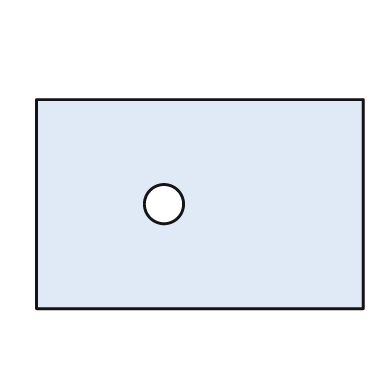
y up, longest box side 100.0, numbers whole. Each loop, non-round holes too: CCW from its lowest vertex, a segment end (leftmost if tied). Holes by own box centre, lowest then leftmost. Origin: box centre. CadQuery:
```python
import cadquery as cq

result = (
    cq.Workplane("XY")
    .moveTo(-50.0, -32.0)
    .lineTo(50.0, -32.0)
    .lineTo(50.0, 32.0)
    .lineTo(-50.0, 32.0)
    .close()
    .moveTo(-11.0, 0.0)
    .circle(6.0)
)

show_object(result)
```